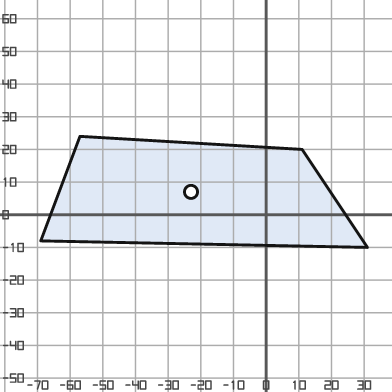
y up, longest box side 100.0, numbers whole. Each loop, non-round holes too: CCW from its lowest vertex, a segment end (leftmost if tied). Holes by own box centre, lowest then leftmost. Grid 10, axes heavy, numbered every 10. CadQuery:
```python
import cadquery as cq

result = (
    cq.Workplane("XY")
    .moveTo(31.0, -10.0)
    .lineTo(11.0, 20.0)
    .lineTo(-57.0, 24.0)
    .lineTo(-69.0, -8.0)
    .close()
    .moveTo(-23.0, 7.0)
    .circle(2.0)
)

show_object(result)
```